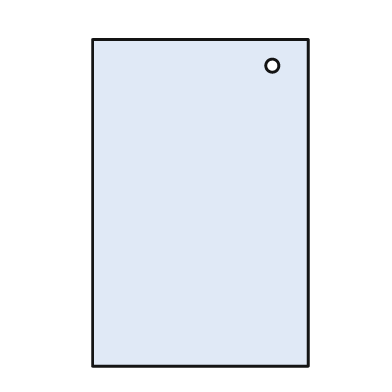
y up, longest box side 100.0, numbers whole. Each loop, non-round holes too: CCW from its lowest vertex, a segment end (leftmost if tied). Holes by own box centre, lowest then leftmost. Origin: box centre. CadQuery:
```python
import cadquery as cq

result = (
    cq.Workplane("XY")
    .moveTo(-33.0, -50.0)
    .lineTo(33.0, -50.0)
    .lineTo(33.0, 50.0)
    .lineTo(-33.0, 50.0)
    .close()
    .moveTo(22.0, 42.0)
    .circle(2.0)
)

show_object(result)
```